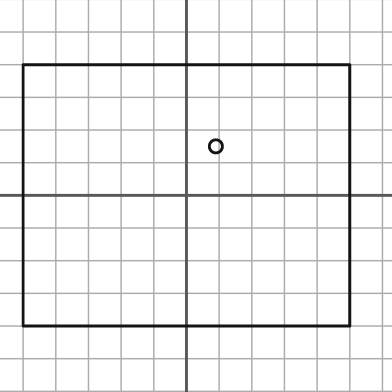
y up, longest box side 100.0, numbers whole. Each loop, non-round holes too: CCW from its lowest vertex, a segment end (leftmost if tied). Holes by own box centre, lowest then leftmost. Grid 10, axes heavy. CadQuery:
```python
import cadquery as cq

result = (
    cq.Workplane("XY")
    .moveTo(-50.0, -40.0)
    .lineTo(50.0, -40.0)
    .lineTo(50.0, 40.0)
    .lineTo(-50.0, 40.0)
    .close()
    .moveTo(9.0, 15.0)
    .circle(2.0)
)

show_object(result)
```